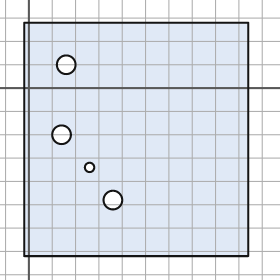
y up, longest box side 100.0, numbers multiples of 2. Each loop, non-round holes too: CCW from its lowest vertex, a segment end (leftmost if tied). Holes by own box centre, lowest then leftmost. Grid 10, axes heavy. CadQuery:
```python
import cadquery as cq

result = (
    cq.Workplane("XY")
    .moveTo(-2.0, -72.0)
    .lineTo(94.0, -72.0)
    .lineTo(94.0, 28.0)
    .lineTo(-2.0, 28.0)
    .close()
    .moveTo(36.0, -48.0)
    .circle(4.0)
    .moveTo(26.0, -34.0)
    .circle(2.0)
    .moveTo(14.0, -20.0)
    .circle(4.0)
    .moveTo(16.0, 10.0)
    .circle(4.0)
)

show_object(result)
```